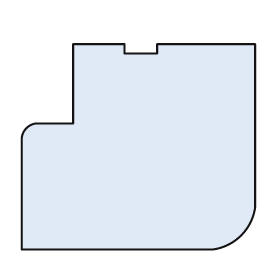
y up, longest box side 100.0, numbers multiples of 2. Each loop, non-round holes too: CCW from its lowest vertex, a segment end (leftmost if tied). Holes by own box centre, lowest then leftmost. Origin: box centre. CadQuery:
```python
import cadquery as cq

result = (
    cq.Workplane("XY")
    .moveTo(-50.0, -44.0)
    .lineTo(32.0, -44.0)
    .threePointArc((44.0, -38.0), (50.0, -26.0))
    .lineTo(50.0, 44.0)
    .lineTo(8.0, 44.0)
    .lineTo(8.0, 40.0)
    .lineTo(-6.0, 40.0)
    .lineTo(-6.0, 44.0)
    .lineTo(-28.0, 44.0)
    .lineTo(-28.0, 10.0)
    .lineTo(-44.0, 10.0)
    .threePointArc((-48.0, 8.0), (-50.0, 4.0))
    .close()
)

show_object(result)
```